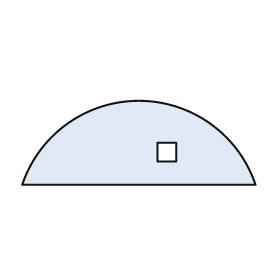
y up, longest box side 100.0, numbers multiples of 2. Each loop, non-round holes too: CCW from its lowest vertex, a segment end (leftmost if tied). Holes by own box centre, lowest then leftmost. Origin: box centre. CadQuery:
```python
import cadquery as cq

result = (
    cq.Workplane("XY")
    .moveTo(-50.0, -18.0)
    .lineTo(50.0, -18.0)
    .threePointArc((0.0, 18.0), (-50.0, -18.0))
    .close()
    .moveTo(8.0, -8.0)
    .lineTo(16.0, -8.0)
    .lineTo(16.0, 0.0)
    .lineTo(8.0, 0.0)
    .close()
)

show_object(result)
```